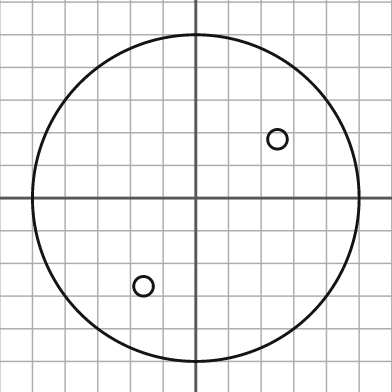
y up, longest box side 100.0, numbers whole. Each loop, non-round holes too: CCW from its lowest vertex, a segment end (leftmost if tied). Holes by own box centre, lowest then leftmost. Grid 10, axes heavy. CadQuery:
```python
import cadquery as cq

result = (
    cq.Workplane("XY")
    .moveTo(0.0, 0.0)
    .circle(50.0)
    .moveTo(-16.0, -27.0)
    .circle(3.0)
    .moveTo(25.0, 18.0)
    .circle(3.0)
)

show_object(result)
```